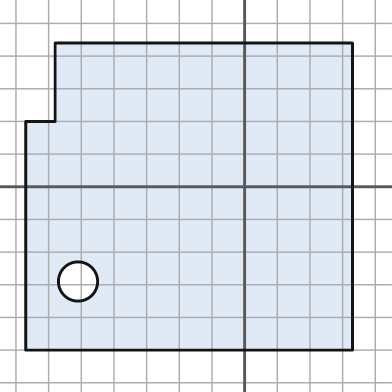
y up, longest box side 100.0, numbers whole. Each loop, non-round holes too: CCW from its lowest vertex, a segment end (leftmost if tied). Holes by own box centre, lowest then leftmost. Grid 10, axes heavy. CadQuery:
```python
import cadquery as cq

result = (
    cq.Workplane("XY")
    .moveTo(-67.0, -50.0)
    .lineTo(33.0, -50.0)
    .lineTo(33.0, 44.0)
    .lineTo(-58.0, 44.0)
    .lineTo(-58.0, 20.0)
    .lineTo(-67.0, 20.0)
    .close()
    .moveTo(-51.0, -29.0)
    .circle(6.0)
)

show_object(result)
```